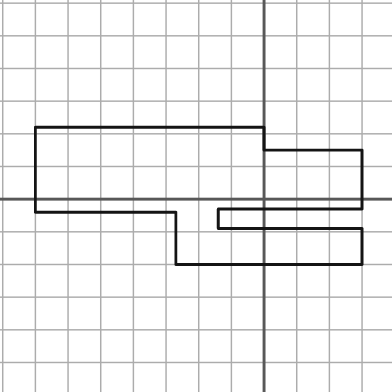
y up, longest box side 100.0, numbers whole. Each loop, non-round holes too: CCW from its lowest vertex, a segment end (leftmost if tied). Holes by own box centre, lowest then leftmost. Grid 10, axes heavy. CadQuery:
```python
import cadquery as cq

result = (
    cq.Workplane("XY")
    .moveTo(-27.0, -20.0)
    .lineTo(30.0, -20.0)
    .lineTo(30.0, -9.0)
    .lineTo(-14.0, -9.0)
    .lineTo(-14.0, -3.0)
    .lineTo(30.0, -3.0)
    .lineTo(30.0, 15.0)
    .lineTo(0.0, 15.0)
    .lineTo(0.0, 22.0)
    .lineTo(-70.0, 22.0)
    .lineTo(-70.0, -4.0)
    .lineTo(-27.0, -4.0)
    .close()
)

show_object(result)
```